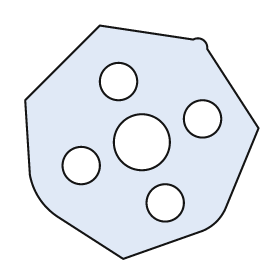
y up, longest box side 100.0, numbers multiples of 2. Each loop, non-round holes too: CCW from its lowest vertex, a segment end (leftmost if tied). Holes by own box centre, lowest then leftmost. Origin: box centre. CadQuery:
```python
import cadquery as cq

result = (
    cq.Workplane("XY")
    .moveTo(-8.0, -50.0)
    .lineTo(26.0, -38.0)
    .threePointArc((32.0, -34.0), (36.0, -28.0))
    .lineTo(50.0, 6.0)
    .lineTo(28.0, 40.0)
    .threePointArc((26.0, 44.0), (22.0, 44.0))
    .lineTo(-18.0, 50.0)
    .lineTo(-50.0, 18.0)
    .lineTo(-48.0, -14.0)
    .threePointArc((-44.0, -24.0), (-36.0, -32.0))
    .close()
    .moveTo(10.0, -26.0)
    .circle(8.0)
    .moveTo(-26.0, -10.0)
    .circle(8.0)
    .moveTo(0.0, 0.0)
    .circle(12.0)
    .moveTo(26.0, 10.0)
    .circle(8.0)
    .moveTo(-10.0, 26.0)
    .circle(8.0)
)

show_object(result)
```